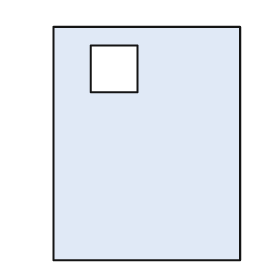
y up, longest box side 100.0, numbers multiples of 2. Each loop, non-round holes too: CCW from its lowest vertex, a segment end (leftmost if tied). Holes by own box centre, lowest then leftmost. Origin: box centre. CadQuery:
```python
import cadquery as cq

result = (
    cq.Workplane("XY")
    .moveTo(-40.0, -50.0)
    .lineTo(40.0, -50.0)
    .lineTo(40.0, 50.0)
    .lineTo(-40.0, 50.0)
    .close()
    .moveTo(-24.0, 22.0)
    .lineTo(-4.0, 22.0)
    .lineTo(-4.0, 42.0)
    .lineTo(-24.0, 42.0)
    .close()
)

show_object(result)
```